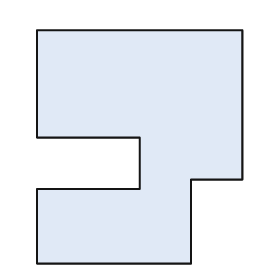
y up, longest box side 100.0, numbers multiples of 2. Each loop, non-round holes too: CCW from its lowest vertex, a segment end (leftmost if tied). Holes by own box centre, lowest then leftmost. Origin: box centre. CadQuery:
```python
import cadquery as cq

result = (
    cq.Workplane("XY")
    .moveTo(-44.0, -50.0)
    .lineTo(22.0, -50.0)
    .lineTo(22.0, -14.0)
    .lineTo(44.0, -14.0)
    .lineTo(44.0, 50.0)
    .lineTo(-44.0, 50.0)
    .lineTo(-44.0, 4.0)
    .lineTo(0.0, 4.0)
    .lineTo(0.0, -18.0)
    .lineTo(-44.0, -18.0)
    .close()
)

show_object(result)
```